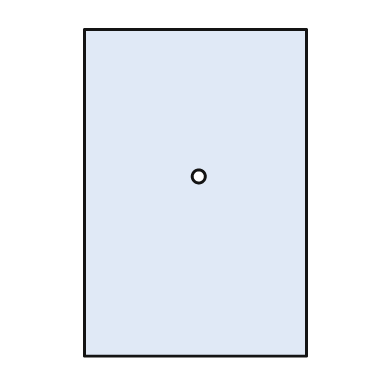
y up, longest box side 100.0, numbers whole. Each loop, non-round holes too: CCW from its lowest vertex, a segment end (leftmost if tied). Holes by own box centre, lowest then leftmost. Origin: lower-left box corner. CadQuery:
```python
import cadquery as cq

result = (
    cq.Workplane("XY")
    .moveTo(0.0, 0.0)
    .lineTo(68.0, 0.0)
    .lineTo(68.0, 100.0)
    .lineTo(0.0, 100.0)
    .close()
    .moveTo(35.0, 55.0)
    .circle(2.0)
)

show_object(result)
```